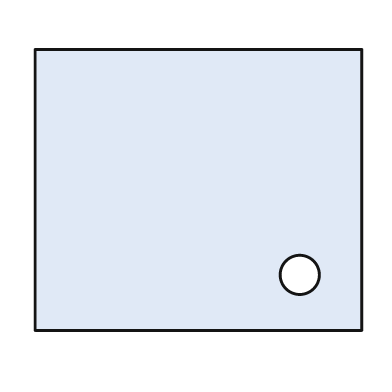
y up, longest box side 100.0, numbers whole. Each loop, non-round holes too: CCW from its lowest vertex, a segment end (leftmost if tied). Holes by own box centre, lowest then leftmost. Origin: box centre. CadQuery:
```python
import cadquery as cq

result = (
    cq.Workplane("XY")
    .moveTo(-50.0, -43.0)
    .lineTo(50.0, -43.0)
    .lineTo(50.0, 43.0)
    .lineTo(-50.0, 43.0)
    .close()
    .moveTo(31.0, -26.0)
    .circle(6.0)
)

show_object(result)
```